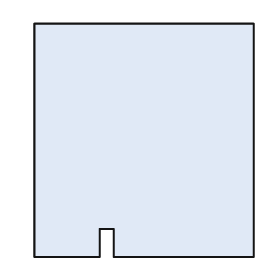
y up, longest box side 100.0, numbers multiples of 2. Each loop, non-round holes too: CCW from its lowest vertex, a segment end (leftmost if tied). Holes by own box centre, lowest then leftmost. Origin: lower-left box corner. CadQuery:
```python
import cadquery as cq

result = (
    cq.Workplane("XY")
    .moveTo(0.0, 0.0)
    .lineTo(28.0, 0.0)
    .lineTo(28.0, 12.0)
    .lineTo(34.0, 12.0)
    .lineTo(34.0, 0.0)
    .lineTo(94.0, 0.0)
    .lineTo(94.0, 100.0)
    .lineTo(0.0, 100.0)
    .close()
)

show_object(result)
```